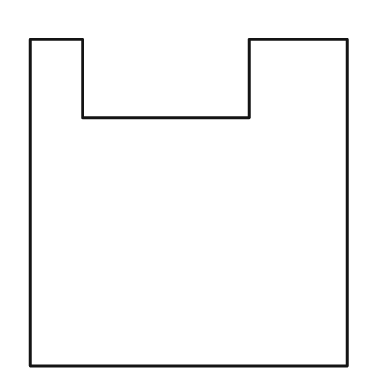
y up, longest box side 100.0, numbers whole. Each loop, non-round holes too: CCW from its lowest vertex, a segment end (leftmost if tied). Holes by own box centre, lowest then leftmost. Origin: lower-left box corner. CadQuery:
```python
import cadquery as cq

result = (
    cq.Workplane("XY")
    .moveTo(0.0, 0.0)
    .lineTo(97.0, 0.0)
    .lineTo(97.0, 100.0)
    .lineTo(67.0, 100.0)
    .lineTo(67.0, 76.0)
    .lineTo(16.0, 76.0)
    .lineTo(16.0, 100.0)
    .lineTo(0.0, 100.0)
    .close()
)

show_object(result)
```